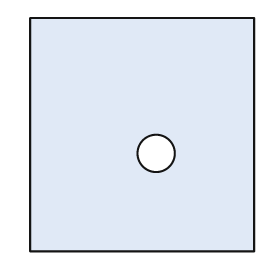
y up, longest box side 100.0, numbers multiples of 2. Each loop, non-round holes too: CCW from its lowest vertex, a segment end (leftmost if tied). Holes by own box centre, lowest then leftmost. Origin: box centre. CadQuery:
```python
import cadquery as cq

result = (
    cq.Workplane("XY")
    .moveTo(-48.0, -50.0)
    .lineTo(48.0, -50.0)
    .lineTo(48.0, 50.0)
    .lineTo(-48.0, 50.0)
    .close()
    .moveTo(6.0, -8.0)
    .circle(8.0)
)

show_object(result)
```